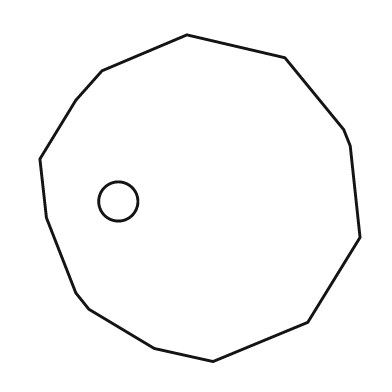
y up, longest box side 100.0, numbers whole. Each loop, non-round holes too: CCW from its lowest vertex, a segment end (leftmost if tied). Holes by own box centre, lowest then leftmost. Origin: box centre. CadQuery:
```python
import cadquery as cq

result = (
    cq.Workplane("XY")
    .moveTo(4.0, -50.0)
    .lineTo(33.0, -38.0)
    .lineTo(49.0, -12.0)
    .lineTo(46.0, 16.0)
    .lineTo(44.0, 21.0)
    .lineTo(26.0, 43.0)
    .lineTo(-4.0, 50.0)
    .lineTo(-30.0, 39.0)
    .lineTo(-38.0, 30.0)
    .lineTo(-49.0, 12.0)
    .lineTo(-47.0, -6.0)
    .lineTo(-38.0, -29.0)
    .lineTo(-34.0, -34.0)
    .lineTo(-14.0, -46.0)
    .close()
    .moveTo(-25.0, -1.0)
    .circle(6.0)
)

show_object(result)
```